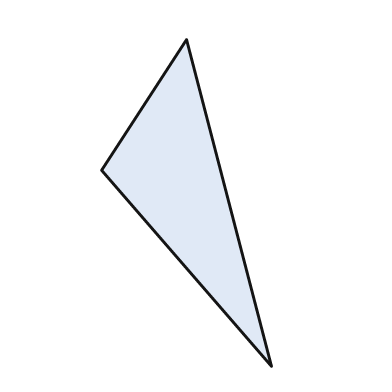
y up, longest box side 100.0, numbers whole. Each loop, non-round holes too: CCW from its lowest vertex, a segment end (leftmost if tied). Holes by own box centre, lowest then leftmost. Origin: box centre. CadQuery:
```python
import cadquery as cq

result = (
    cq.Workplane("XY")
    .moveTo(26.0, -50.0)
    .lineTo(0.0, 50.0)
    .lineTo(-26.0, 10.0)
    .close()
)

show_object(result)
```